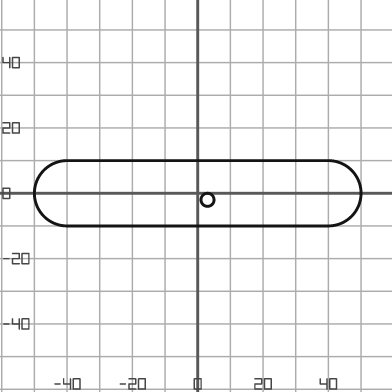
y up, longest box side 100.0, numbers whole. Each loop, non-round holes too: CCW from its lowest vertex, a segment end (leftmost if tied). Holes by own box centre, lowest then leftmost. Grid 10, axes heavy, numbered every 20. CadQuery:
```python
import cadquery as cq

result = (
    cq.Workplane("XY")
    .moveTo(-40.0, -10.0)
    .lineTo(40.0, -10.0)
    .threePointArc((50.0, 0.0), (40.0, 10.0))
    .lineTo(-40.0, 10.0)
    .threePointArc((-50.0, 0.0), (-40.0, -10.0))
    .close()
    .moveTo(3.0, -2.0)
    .circle(2.0)
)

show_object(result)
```